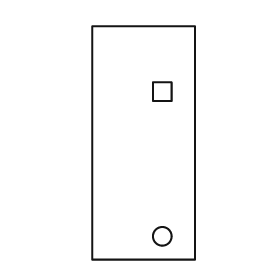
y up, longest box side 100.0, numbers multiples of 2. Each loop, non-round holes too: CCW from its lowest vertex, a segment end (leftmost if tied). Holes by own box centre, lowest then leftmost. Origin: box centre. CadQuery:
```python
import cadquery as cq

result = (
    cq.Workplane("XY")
    .moveTo(-22.0, -50.0)
    .lineTo(22.0, -50.0)
    .lineTo(22.0, 50.0)
    .lineTo(-22.0, 50.0)
    .close()
    .moveTo(8.0, -40.0)
    .circle(4.0)
    .moveTo(4.0, 18.0)
    .lineTo(12.0, 18.0)
    .lineTo(12.0, 26.0)
    .lineTo(4.0, 26.0)
    .close()
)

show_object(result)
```